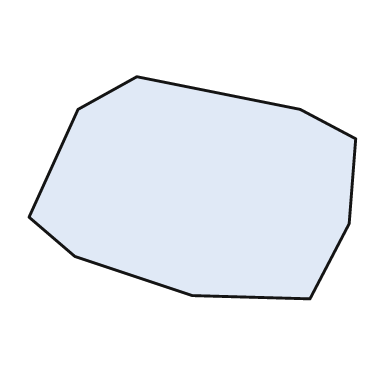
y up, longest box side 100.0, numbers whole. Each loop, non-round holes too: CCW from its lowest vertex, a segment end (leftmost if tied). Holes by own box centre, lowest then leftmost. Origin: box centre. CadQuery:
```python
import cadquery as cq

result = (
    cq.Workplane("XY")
    .moveTo(36.0, -34.0)
    .lineTo(48.0, -11.0)
    .lineTo(50.0, 15.0)
    .lineTo(33.0, 24.0)
    .lineTo(-17.0, 34.0)
    .lineTo(-35.0, 24.0)
    .lineTo(-50.0, -9.0)
    .lineTo(-36.0, -21.0)
    .lineTo(0.0, -33.0)
    .close()
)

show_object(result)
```